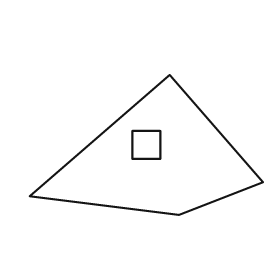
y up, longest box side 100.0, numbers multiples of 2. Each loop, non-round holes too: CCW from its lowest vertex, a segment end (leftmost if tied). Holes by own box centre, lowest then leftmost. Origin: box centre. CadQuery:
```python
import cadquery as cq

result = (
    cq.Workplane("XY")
    .moveTo(14.0, -30.0)
    .lineTo(50.0, -16.0)
    .lineTo(10.0, 30.0)
    .lineTo(-50.0, -22.0)
    .close()
    .moveTo(-6.0, -6.0)
    .lineTo(6.0, -6.0)
    .lineTo(6.0, 6.0)
    .lineTo(-6.0, 6.0)
    .close()
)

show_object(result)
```